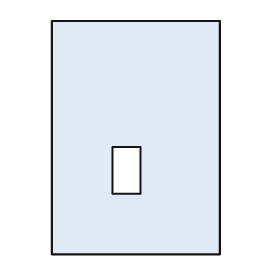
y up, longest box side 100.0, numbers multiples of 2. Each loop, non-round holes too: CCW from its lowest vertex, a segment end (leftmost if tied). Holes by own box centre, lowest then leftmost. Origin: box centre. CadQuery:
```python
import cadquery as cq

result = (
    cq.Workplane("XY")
    .moveTo(-36.0, -50.0)
    .lineTo(36.0, -50.0)
    .lineTo(36.0, 50.0)
    .lineTo(-36.0, 50.0)
    .close()
    .moveTo(-10.0, -24.0)
    .lineTo(2.0, -24.0)
    .lineTo(2.0, -4.0)
    .lineTo(-10.0, -4.0)
    .close()
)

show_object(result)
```